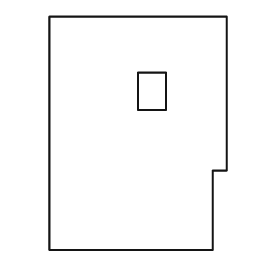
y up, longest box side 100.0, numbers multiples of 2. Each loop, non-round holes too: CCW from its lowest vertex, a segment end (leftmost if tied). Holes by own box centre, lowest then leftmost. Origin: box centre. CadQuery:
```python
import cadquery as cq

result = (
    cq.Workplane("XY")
    .moveTo(-38.0, -50.0)
    .lineTo(32.0, -50.0)
    .lineTo(32.0, -16.0)
    .lineTo(38.0, -16.0)
    .lineTo(38.0, 50.0)
    .lineTo(-38.0, 50.0)
    .close()
    .moveTo(0.0, 10.0)
    .lineTo(12.0, 10.0)
    .lineTo(12.0, 26.0)
    .lineTo(0.0, 26.0)
    .close()
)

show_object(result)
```